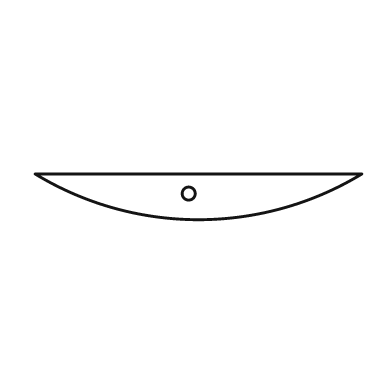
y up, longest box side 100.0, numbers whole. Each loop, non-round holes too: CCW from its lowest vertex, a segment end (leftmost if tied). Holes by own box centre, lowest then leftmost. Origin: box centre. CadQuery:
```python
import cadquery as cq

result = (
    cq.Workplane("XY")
    .moveTo(-50.0, 7.0)
    .threePointArc((0.0, -7.0), (50.0, 7.0))
    .close()
    .moveTo(-3.0, 1.0)
    .circle(2.0)
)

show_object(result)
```